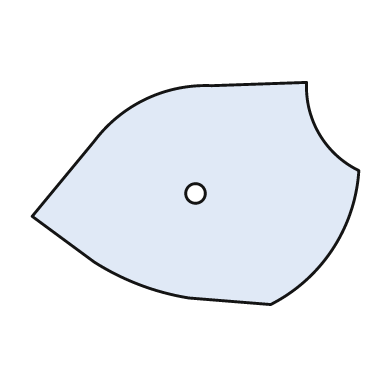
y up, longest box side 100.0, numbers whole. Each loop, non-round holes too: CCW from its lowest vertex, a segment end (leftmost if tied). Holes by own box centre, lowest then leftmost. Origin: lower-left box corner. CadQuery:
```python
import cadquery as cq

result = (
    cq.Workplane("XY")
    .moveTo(73.0, 0.0)
    .threePointArc((92.0, 17.0), (100.0, 41.0))
    .threePointArc((88.0, 52.0), (84.0, 68.0))
    .lineTo(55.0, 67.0)
    .threePointArc((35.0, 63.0), (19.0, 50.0))
    .lineTo(0.0, 27.0)
    .lineTo(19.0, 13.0)
    .threePointArc((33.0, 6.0), (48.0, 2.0))
    .close()
    .moveTo(50.0, 34.0)
    .circle(3.0)
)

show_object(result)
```